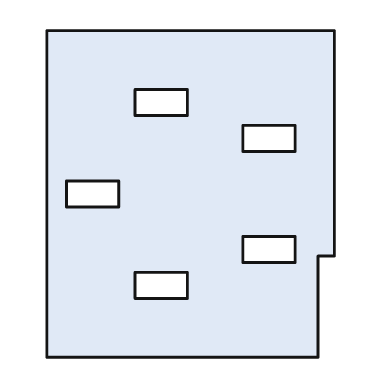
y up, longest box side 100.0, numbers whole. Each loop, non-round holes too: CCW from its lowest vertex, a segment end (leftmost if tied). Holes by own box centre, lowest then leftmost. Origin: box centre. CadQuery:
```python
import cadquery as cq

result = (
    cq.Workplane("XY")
    .moveTo(-44.0, -50.0)
    .lineTo(39.0, -50.0)
    .lineTo(39.0, -19.0)
    .lineTo(44.0, -19.0)
    .lineTo(44.0, 50.0)
    .lineTo(-44.0, 50.0)
    .close()
    .moveTo(-17.0, -32.0)
    .lineTo(-1.0, -32.0)
    .lineTo(-1.0, -24.0)
    .lineTo(-17.0, -24.0)
    .close()
    .moveTo(16.0, -21.0)
    .lineTo(32.0, -21.0)
    .lineTo(32.0, -13.0)
    .lineTo(16.0, -13.0)
    .close()
    .moveTo(-38.0, -4.0)
    .lineTo(-22.0, -4.0)
    .lineTo(-22.0, 4.0)
    .lineTo(-38.0, 4.0)
    .close()
    .moveTo(16.0, 13.0)
    .lineTo(32.0, 13.0)
    .lineTo(32.0, 21.0)
    .lineTo(16.0, 21.0)
    .close()
    .moveTo(-17.0, 24.0)
    .lineTo(-1.0, 24.0)
    .lineTo(-1.0, 32.0)
    .lineTo(-17.0, 32.0)
    .close()
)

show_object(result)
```